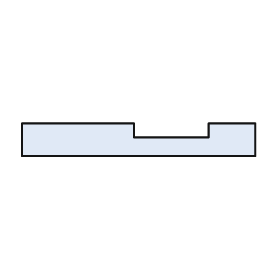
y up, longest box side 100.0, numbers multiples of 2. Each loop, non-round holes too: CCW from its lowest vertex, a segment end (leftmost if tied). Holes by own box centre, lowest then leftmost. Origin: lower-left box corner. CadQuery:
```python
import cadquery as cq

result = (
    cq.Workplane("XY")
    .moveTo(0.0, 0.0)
    .lineTo(100.0, 0.0)
    .lineTo(100.0, 14.0)
    .lineTo(80.0, 14.0)
    .lineTo(80.0, 8.0)
    .lineTo(48.0, 8.0)
    .lineTo(48.0, 14.0)
    .lineTo(0.0, 14.0)
    .close()
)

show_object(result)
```